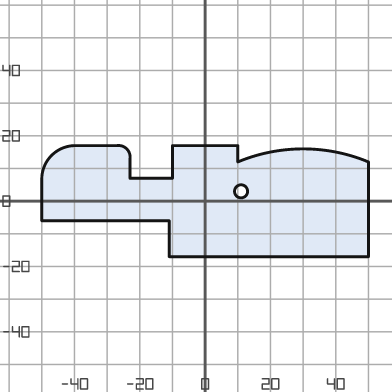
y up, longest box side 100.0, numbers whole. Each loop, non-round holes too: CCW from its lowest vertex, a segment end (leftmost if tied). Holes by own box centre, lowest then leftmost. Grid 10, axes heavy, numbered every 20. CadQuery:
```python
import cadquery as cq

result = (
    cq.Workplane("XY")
    .moveTo(-11.0, -17.0)
    .lineTo(50.0, -17.0)
    .lineTo(50.0, 12.0)
    .threePointArc((30.0, 16.0), (10.0, 12.0))
    .lineTo(10.0, 17.0)
    .lineTo(-10.0, 17.0)
    .lineTo(-10.0, 7.0)
    .lineTo(-23.0, 7.0)
    .lineTo(-23.0, 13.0)
    .threePointArc((-24.0, 16.0), (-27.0, 17.0))
    .lineTo(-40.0, 17.0)
    .threePointArc((-47.0, 14.0), (-50.0, 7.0))
    .lineTo(-50.0, -6.0)
    .lineTo(-11.0, -6.0)
    .close()
    .moveTo(11.0, 3.0)
    .circle(2.0)
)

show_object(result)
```